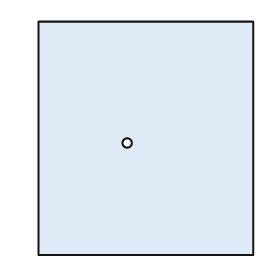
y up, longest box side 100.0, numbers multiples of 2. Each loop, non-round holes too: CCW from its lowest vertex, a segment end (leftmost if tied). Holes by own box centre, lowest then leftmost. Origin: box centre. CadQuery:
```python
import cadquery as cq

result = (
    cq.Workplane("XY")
    .moveTo(-46.0, -50.0)
    .lineTo(46.0, -50.0)
    .lineTo(46.0, 50.0)
    .lineTo(-46.0, 50.0)
    .close()
    .moveTo(-8.0, -2.0)
    .circle(2.0)
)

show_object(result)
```